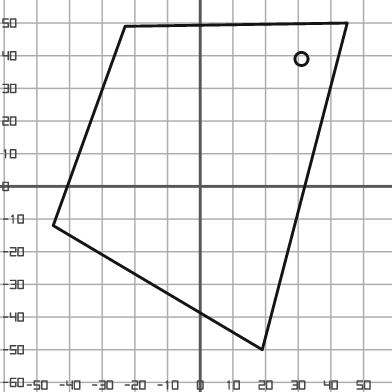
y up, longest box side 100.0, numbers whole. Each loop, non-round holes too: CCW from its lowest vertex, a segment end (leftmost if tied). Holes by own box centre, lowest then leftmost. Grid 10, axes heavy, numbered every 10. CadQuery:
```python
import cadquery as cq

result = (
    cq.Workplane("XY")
    .moveTo(19.0, -50.0)
    .lineTo(45.0, 50.0)
    .lineTo(-23.0, 49.0)
    .lineTo(-45.0, -12.0)
    .close()
    .moveTo(31.0, 39.0)
    .circle(2.0)
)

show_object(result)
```